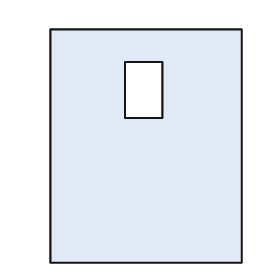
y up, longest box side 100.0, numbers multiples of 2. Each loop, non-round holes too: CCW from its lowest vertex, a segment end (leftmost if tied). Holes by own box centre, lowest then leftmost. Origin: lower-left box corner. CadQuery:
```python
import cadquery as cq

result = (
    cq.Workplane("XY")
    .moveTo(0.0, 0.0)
    .lineTo(82.0, 0.0)
    .lineTo(82.0, 100.0)
    .lineTo(0.0, 100.0)
    .close()
    .moveTo(32.0, 62.0)
    .lineTo(48.0, 62.0)
    .lineTo(48.0, 86.0)
    .lineTo(32.0, 86.0)
    .close()
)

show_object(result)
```